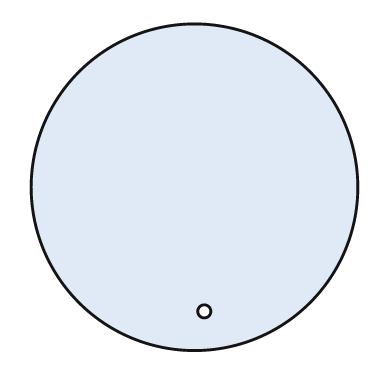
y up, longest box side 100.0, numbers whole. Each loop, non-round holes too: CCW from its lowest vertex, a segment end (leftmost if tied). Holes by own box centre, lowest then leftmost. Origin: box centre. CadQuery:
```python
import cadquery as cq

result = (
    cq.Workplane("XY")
    .moveTo(0.0, 0.0)
    .circle(50.0)
    .moveTo(3.0, -38.0)
    .circle(2.0)
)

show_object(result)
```